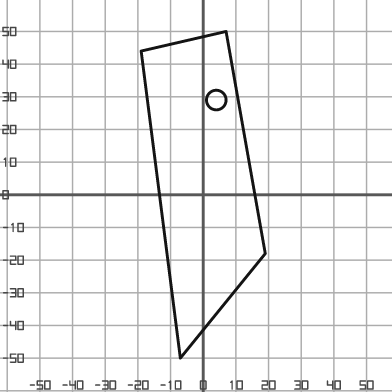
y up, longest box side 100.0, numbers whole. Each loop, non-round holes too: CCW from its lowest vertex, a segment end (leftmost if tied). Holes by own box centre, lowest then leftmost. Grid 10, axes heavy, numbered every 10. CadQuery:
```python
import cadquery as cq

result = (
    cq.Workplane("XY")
    .moveTo(-7.0, -50.0)
    .lineTo(19.0, -18.0)
    .lineTo(7.0, 50.0)
    .lineTo(-19.0, 44.0)
    .close()
    .moveTo(4.0, 29.0)
    .circle(3.0)
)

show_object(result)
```